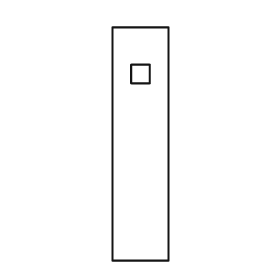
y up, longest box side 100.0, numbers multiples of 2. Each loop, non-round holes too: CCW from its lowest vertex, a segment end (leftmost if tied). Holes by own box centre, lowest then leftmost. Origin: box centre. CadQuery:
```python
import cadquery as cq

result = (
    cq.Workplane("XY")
    .moveTo(-12.0, -50.0)
    .lineTo(12.0, -50.0)
    .lineTo(12.0, 50.0)
    .lineTo(-12.0, 50.0)
    .close()
    .moveTo(-4.0, 26.0)
    .lineTo(4.0, 26.0)
    .lineTo(4.0, 34.0)
    .lineTo(-4.0, 34.0)
    .close()
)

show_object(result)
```